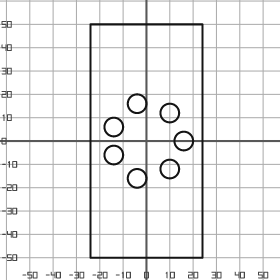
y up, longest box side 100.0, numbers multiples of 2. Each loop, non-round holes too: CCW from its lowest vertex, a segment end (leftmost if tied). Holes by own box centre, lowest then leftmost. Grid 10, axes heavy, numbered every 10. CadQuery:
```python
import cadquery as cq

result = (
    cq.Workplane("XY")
    .moveTo(-24.0, -50.0)
    .lineTo(24.0, -50.0)
    .lineTo(24.0, 50.0)
    .lineTo(-24.0, 50.0)
    .close()
    .moveTo(-4.0, -16.0)
    .circle(4.0)
    .moveTo(10.0, -12.0)
    .circle(4.0)
    .moveTo(-14.0, -6.0)
    .circle(4.0)
    .moveTo(16.0, 0.0)
    .circle(4.0)
    .moveTo(-14.0, 6.0)
    .circle(4.0)
    .moveTo(10.0, 12.0)
    .circle(4.0)
    .moveTo(-4.0, 16.0)
    .circle(4.0)
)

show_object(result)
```